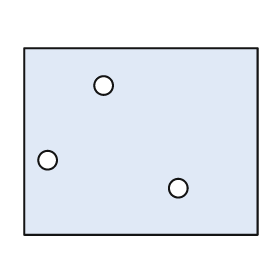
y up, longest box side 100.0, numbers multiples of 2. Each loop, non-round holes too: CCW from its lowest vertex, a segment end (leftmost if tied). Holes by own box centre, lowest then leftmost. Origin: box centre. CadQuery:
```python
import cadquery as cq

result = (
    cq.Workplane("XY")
    .moveTo(-50.0, -40.0)
    .lineTo(50.0, -40.0)
    .lineTo(50.0, 40.0)
    .lineTo(-50.0, 40.0)
    .close()
    .moveTo(16.0, -20.0)
    .circle(4.0)
    .moveTo(-40.0, -8.0)
    .circle(4.0)
    .moveTo(-16.0, 24.0)
    .circle(4.0)
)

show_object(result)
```